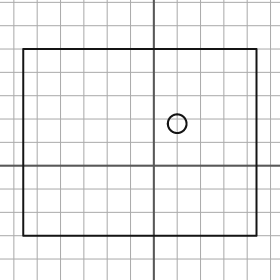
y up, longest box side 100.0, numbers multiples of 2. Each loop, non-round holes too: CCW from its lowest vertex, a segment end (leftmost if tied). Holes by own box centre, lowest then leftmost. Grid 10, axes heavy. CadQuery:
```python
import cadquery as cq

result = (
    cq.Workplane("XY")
    .moveTo(-56.0, -30.0)
    .lineTo(44.0, -30.0)
    .lineTo(44.0, 50.0)
    .lineTo(-56.0, 50.0)
    .close()
    .moveTo(10.0, 18.0)
    .circle(4.0)
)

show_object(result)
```